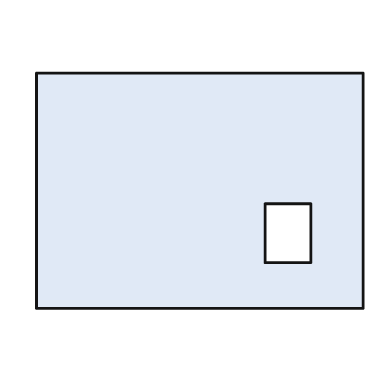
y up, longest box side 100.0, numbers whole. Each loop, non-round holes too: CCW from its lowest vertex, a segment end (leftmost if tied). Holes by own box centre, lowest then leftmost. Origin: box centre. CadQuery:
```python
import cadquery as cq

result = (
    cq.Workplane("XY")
    .moveTo(-50.0, -36.0)
    .lineTo(50.0, -36.0)
    .lineTo(50.0, 36.0)
    .lineTo(-50.0, 36.0)
    .close()
    .moveTo(20.0, -22.0)
    .lineTo(34.0, -22.0)
    .lineTo(34.0, -4.0)
    .lineTo(20.0, -4.0)
    .close()
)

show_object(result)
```